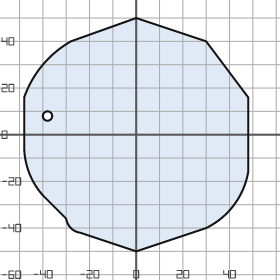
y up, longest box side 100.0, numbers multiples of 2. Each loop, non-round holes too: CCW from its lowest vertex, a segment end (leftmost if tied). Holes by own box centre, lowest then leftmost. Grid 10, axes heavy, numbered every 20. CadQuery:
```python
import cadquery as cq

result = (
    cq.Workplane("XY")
    .moveTo(0.0, -50.0)
    .lineTo(30.0, -40.0)
    .threePointArc((42.0, -30.0), (48.0, -16.0))
    .lineTo(48.0, 16.0)
    .lineTo(30.0, 40.0)
    .lineTo(0.0, 50.0)
    .lineTo(-28.0, 40.0)
    .threePointArc((-40.0, 30.0), (-48.0, 16.0))
    .lineTo(-48.0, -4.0)
    .threePointArc((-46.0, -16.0), (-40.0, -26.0))
    .lineTo(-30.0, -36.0)
    .threePointArc((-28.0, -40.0), (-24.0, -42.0))
    .close()
    .moveTo(-38.0, 8.0)
    .circle(2.0)
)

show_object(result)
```